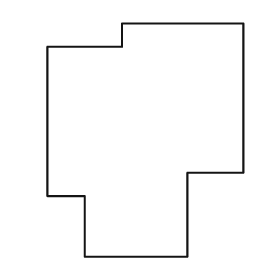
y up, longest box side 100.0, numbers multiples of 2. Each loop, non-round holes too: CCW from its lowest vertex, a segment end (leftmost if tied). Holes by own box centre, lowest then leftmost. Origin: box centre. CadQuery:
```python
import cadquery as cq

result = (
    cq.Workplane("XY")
    .moveTo(-26.0, -50.0)
    .lineTo(18.0, -50.0)
    .lineTo(18.0, -14.0)
    .lineTo(42.0, -14.0)
    .lineTo(42.0, 50.0)
    .lineTo(-10.0, 50.0)
    .lineTo(-10.0, 40.0)
    .lineTo(-42.0, 40.0)
    .lineTo(-42.0, -24.0)
    .lineTo(-26.0, -24.0)
    .close()
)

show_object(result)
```